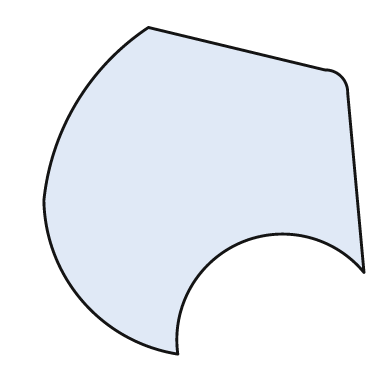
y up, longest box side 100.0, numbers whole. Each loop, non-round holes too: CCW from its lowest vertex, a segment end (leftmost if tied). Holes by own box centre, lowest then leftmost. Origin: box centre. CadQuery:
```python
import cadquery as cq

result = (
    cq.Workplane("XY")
    .moveTo(-8.0, -50.0)
    .threePointArc((11.0, -16.0), (49.0, -25.0))
    .lineTo(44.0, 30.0)
    .threePointArc((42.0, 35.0), (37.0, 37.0))
    .lineTo(-17.0, 50.0)
    .threePointArc((-39.0, 27.0), (-49.0, -3.0))
    .threePointArc((-37.0, -34.0), (-8.0, -50.0))
    .close()
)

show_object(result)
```